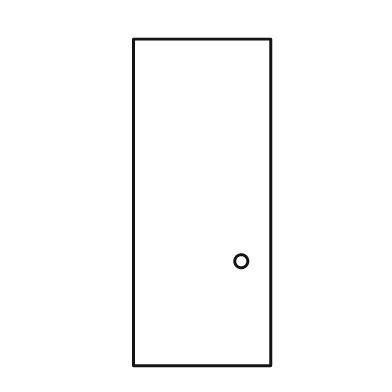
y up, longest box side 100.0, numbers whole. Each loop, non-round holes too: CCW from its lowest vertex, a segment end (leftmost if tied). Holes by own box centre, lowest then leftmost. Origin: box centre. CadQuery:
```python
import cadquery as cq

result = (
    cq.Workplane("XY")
    .moveTo(-21.0, -50.0)
    .lineTo(21.0, -50.0)
    .lineTo(21.0, 50.0)
    .lineTo(-21.0, 50.0)
    .close()
    .moveTo(12.0, -18.0)
    .circle(2.0)
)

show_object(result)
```